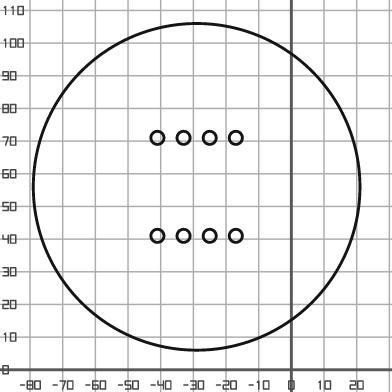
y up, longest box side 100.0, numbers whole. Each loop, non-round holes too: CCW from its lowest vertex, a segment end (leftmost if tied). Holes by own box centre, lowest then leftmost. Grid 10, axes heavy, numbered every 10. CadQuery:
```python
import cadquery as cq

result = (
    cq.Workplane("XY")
    .moveTo(-29.0, 56.0)
    .circle(50.0)
    .moveTo(-41.0, 41.0)
    .circle(2.0)
    .moveTo(-33.0, 41.0)
    .circle(2.0)
    .moveTo(-25.0, 41.0)
    .circle(2.0)
    .moveTo(-17.0, 41.0)
    .circle(2.0)
    .moveTo(-41.0, 71.0)
    .circle(2.0)
    .moveTo(-33.0, 71.0)
    .circle(2.0)
    .moveTo(-25.0, 71.0)
    .circle(2.0)
    .moveTo(-17.0, 71.0)
    .circle(2.0)
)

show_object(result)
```